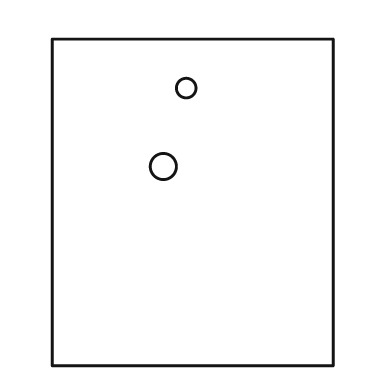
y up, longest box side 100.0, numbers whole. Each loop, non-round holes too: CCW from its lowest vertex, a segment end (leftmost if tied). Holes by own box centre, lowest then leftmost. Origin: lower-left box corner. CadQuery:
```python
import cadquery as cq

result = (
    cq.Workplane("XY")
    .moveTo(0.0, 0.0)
    .lineTo(86.0, 0.0)
    .lineTo(86.0, 100.0)
    .lineTo(0.0, 100.0)
    .close()
    .moveTo(34.0, 61.0)
    .circle(4.0)
    .moveTo(41.0, 85.0)
    .circle(3.0)
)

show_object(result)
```